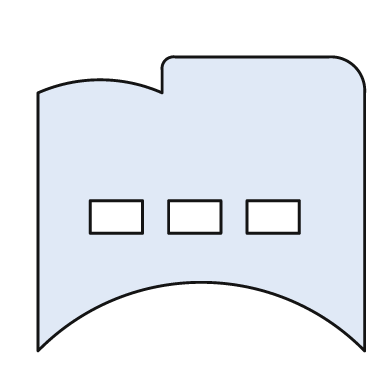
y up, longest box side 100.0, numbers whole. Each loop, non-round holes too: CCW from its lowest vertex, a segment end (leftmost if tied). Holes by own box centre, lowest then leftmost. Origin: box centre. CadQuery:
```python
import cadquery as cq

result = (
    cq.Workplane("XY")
    .moveTo(-50.0, -45.0)
    .threePointArc((0.0, -24.0), (50.0, -45.0))
    .lineTo(50.0, 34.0)
    .threePointArc((47.0, 42.0), (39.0, 45.0))
    .lineTo(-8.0, 45.0)
    .threePointArc((-11.0, 44.0), (-12.0, 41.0))
    .lineTo(-12.0, 34.0)
    .threePointArc((-31.0, 38.0), (-50.0, 34.0))
    .close()
    .moveTo(-34.0, -9.0)
    .lineTo(-18.0, -9.0)
    .lineTo(-18.0, 1.0)
    .lineTo(-34.0, 1.0)
    .close()
    .moveTo(-10.0, -9.0)
    .lineTo(6.0, -9.0)
    .lineTo(6.0, 1.0)
    .lineTo(-10.0, 1.0)
    .close()
    .moveTo(14.0, -9.0)
    .lineTo(30.0, -9.0)
    .lineTo(30.0, 1.0)
    .lineTo(14.0, 1.0)
    .close()
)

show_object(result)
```